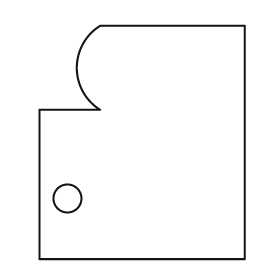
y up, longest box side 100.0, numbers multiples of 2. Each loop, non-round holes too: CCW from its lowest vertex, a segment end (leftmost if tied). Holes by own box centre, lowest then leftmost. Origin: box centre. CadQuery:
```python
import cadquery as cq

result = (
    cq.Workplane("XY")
    .moveTo(-44.0, -50.0)
    .lineTo(44.0, -50.0)
    .lineTo(44.0, 50.0)
    .lineTo(-18.0, 50.0)
    .threePointArc((-28.0, 32.0), (-18.0, 14.0))
    .lineTo(-44.0, 14.0)
    .close()
    .moveTo(-32.0, -24.0)
    .circle(6.0)
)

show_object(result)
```